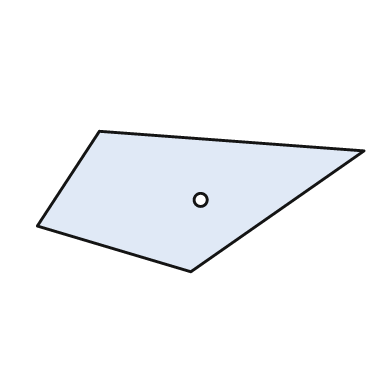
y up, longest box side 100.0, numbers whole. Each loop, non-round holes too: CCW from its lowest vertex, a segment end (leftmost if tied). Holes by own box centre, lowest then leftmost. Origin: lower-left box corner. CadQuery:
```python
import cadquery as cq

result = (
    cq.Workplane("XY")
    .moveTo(47.0, 0.0)
    .lineTo(100.0, 37.0)
    .lineTo(19.0, 43.0)
    .lineTo(0.0, 14.0)
    .close()
    .moveTo(50.0, 22.0)
    .circle(2.0)
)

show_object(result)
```